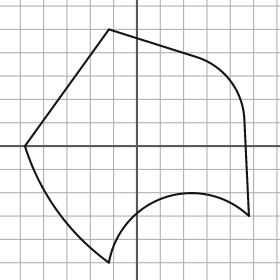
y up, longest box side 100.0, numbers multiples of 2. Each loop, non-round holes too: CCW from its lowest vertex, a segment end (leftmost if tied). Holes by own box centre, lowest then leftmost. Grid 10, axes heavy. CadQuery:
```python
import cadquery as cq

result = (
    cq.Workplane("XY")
    .moveTo(-12.0, -50.0)
    .threePointArc((12.0, -22.0), (48.0, -30.0))
    .lineTo(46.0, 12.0)
    .threePointArc((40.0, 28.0), (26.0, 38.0))
    .lineTo(-12.0, 50.0)
    .lineTo(-48.0, 0.0)
    .threePointArc((-34.0, -28.0), (-12.0, -50.0))
    .close()
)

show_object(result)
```